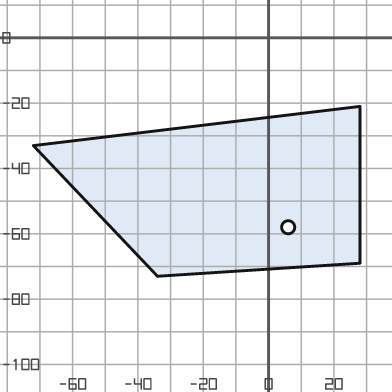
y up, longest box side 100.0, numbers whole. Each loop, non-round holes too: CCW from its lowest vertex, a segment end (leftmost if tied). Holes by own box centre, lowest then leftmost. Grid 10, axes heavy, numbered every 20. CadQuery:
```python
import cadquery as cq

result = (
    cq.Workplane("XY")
    .moveTo(-34.0, -73.0)
    .lineTo(28.0, -69.0)
    .lineTo(28.0, -21.0)
    .lineTo(-72.0, -33.0)
    .close()
    .moveTo(6.0, -58.0)
    .circle(2.0)
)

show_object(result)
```